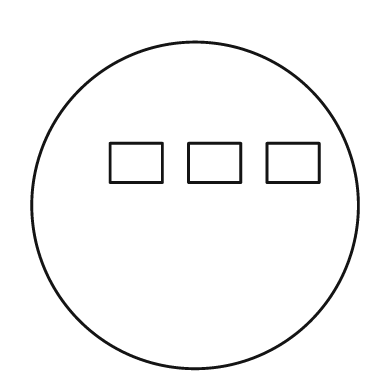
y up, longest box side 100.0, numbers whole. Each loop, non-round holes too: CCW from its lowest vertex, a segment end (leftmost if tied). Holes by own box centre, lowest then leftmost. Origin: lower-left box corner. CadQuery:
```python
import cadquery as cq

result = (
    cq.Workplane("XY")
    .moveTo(50.0, 50.0)
    .circle(50.0)
    .moveTo(24.0, 57.0)
    .lineTo(40.0, 57.0)
    .lineTo(40.0, 69.0)
    .lineTo(24.0, 69.0)
    .close()
    .moveTo(48.0, 57.0)
    .lineTo(64.0, 57.0)
    .lineTo(64.0, 69.0)
    .lineTo(48.0, 69.0)
    .close()
    .moveTo(72.0, 57.0)
    .lineTo(88.0, 57.0)
    .lineTo(88.0, 69.0)
    .lineTo(72.0, 69.0)
    .close()
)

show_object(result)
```